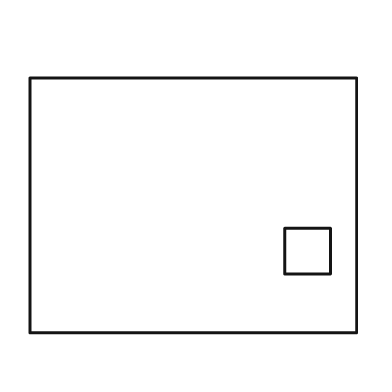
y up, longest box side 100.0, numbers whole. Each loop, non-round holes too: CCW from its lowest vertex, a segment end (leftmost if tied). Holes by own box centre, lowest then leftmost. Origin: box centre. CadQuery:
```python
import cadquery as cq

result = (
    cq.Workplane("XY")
    .moveTo(-50.0, -39.0)
    .lineTo(50.0, -39.0)
    .lineTo(50.0, 39.0)
    .lineTo(-50.0, 39.0)
    .close()
    .moveTo(28.0, -21.0)
    .lineTo(42.0, -21.0)
    .lineTo(42.0, -7.0)
    .lineTo(28.0, -7.0)
    .close()
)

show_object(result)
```